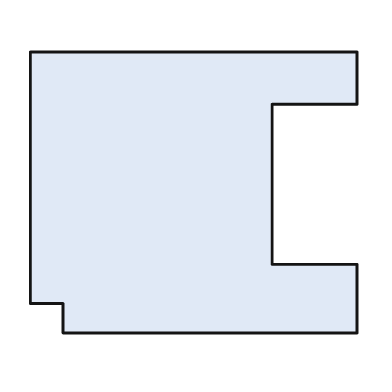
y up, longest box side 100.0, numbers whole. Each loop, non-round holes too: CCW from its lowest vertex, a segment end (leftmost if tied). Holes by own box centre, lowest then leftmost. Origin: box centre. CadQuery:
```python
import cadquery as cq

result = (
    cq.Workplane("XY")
    .moveTo(-40.0, -43.0)
    .lineTo(50.0, -43.0)
    .lineTo(50.0, -22.0)
    .lineTo(24.0, -22.0)
    .lineTo(24.0, 27.0)
    .lineTo(50.0, 27.0)
    .lineTo(50.0, 43.0)
    .lineTo(-50.0, 43.0)
    .lineTo(-50.0, -34.0)
    .lineTo(-40.0, -34.0)
    .close()
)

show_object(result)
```